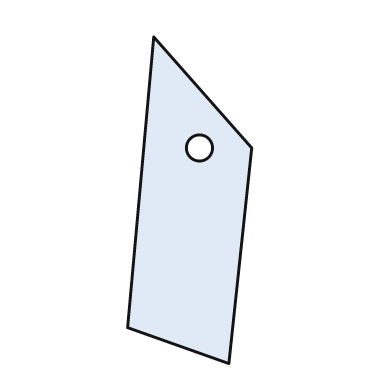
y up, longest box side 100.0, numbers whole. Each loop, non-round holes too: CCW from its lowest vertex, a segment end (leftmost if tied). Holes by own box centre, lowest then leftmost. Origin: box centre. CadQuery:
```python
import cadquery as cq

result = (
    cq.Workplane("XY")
    .moveTo(12.0, -50.0)
    .lineTo(19.0, 16.0)
    .lineTo(-11.0, 50.0)
    .lineTo(-19.0, -39.0)
    .close()
    .moveTo(3.0, 16.0)
    .circle(4.0)
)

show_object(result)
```